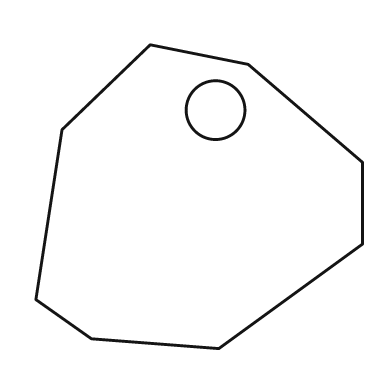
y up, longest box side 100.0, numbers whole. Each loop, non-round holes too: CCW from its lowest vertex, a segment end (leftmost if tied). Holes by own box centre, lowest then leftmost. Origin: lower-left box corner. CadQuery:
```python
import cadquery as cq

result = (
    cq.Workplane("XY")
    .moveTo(56.0, 0.0)
    .lineTo(100.0, 32.0)
    .lineTo(100.0, 57.0)
    .lineTo(65.0, 87.0)
    .lineTo(35.0, 93.0)
    .lineTo(8.0, 67.0)
    .lineTo(0.0, 15.0)
    .lineTo(17.0, 3.0)
    .close()
    .moveTo(55.0, 73.0)
    .circle(9.0)
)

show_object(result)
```